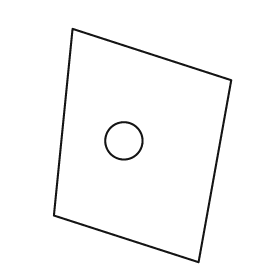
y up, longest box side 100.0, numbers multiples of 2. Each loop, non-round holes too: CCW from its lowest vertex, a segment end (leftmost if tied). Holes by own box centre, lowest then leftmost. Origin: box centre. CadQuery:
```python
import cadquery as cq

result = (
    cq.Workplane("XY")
    .moveTo(24.0, -50.0)
    .lineTo(38.0, 28.0)
    .lineTo(-30.0, 50.0)
    .lineTo(-38.0, -30.0)
    .close()
    .moveTo(-8.0, 2.0)
    .circle(8.0)
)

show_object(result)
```